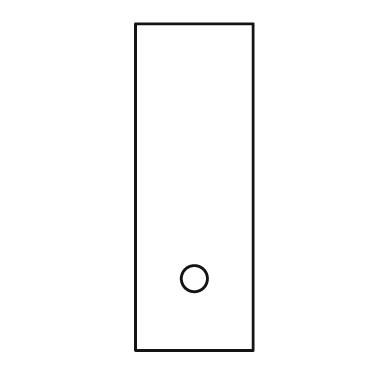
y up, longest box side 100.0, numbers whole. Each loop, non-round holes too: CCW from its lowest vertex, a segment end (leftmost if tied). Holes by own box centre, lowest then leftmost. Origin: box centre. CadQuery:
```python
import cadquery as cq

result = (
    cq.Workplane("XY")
    .moveTo(-18.0, -50.0)
    .lineTo(18.0, -50.0)
    .lineTo(18.0, 50.0)
    .lineTo(-18.0, 50.0)
    .close()
    .moveTo(0.0, -28.0)
    .circle(4.0)
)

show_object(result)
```